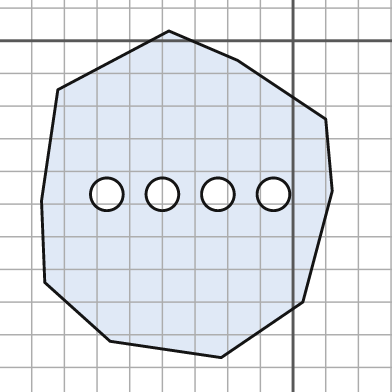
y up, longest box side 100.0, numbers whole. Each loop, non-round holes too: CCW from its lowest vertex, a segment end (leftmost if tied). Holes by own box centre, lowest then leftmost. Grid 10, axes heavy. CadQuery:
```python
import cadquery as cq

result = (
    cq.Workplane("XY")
    .moveTo(-22.0, -97.0)
    .lineTo(3.0, -80.0)
    .lineTo(12.0, -46.0)
    .lineTo(10.0, -24.0)
    .lineTo(-17.0, -6.0)
    .lineTo(-38.0, 3.0)
    .lineTo(-72.0, -15.0)
    .lineTo(-77.0, -49.0)
    .lineTo(-76.0, -74.0)
    .lineTo(-56.0, -92.0)
    .close()
    .moveTo(-57.0, -47.0)
    .circle(5.0)
    .moveTo(-40.0, -47.0)
    .circle(5.0)
    .moveTo(-23.0, -47.0)
    .circle(5.0)
    .moveTo(-6.0, -47.0)
    .circle(5.0)
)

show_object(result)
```